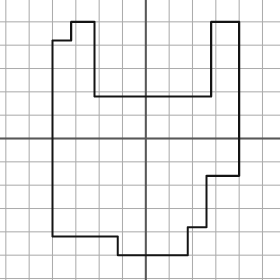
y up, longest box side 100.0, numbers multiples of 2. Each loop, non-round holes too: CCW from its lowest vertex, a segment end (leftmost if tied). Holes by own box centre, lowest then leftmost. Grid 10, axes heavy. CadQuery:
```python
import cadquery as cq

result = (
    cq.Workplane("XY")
    .moveTo(-12.0, -50.0)
    .lineTo(18.0, -50.0)
    .lineTo(18.0, -38.0)
    .lineTo(26.0, -38.0)
    .lineTo(26.0, -16.0)
    .lineTo(40.0, -16.0)
    .lineTo(40.0, 50.0)
    .lineTo(28.0, 50.0)
    .lineTo(28.0, 18.0)
    .lineTo(-22.0, 18.0)
    .lineTo(-22.0, 50.0)
    .lineTo(-32.0, 50.0)
    .lineTo(-32.0, 42.0)
    .lineTo(-40.0, 42.0)
    .lineTo(-40.0, -42.0)
    .lineTo(-12.0, -42.0)
    .close()
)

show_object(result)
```